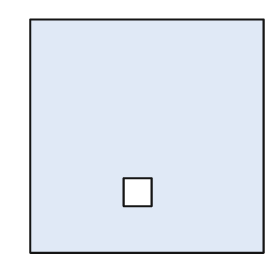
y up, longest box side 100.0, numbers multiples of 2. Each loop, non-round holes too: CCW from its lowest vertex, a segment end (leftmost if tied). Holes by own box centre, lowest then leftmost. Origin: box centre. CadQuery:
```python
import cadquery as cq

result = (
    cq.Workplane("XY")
    .moveTo(-50.0, -50.0)
    .lineTo(50.0, -50.0)
    .lineTo(50.0, 50.0)
    .lineTo(-50.0, 50.0)
    .close()
    .moveTo(-10.0, -30.0)
    .lineTo(2.0, -30.0)
    .lineTo(2.0, -18.0)
    .lineTo(-10.0, -18.0)
    .close()
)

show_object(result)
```